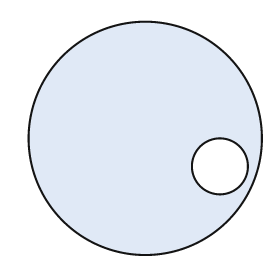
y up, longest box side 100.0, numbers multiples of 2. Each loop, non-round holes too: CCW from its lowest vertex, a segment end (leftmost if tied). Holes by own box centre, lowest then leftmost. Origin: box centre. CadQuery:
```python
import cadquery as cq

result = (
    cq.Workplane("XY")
    .moveTo(0.0, 0.0)
    .circle(50.0)
    .moveTo(32.0, -12.0)
    .circle(12.0)
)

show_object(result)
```